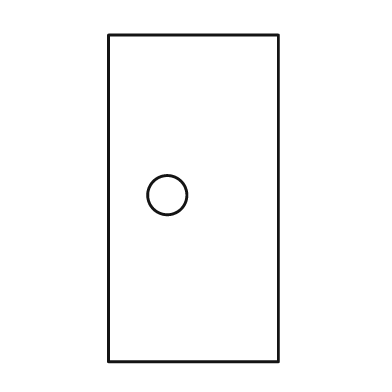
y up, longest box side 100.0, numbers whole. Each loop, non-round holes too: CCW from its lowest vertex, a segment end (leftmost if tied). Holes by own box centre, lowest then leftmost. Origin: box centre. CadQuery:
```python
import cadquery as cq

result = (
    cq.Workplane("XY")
    .moveTo(-26.0, -50.0)
    .lineTo(26.0, -50.0)
    .lineTo(26.0, 50.0)
    .lineTo(-26.0, 50.0)
    .close()
    .moveTo(-8.0, 1.0)
    .circle(6.0)
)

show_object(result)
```